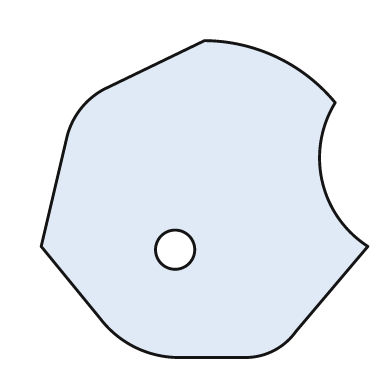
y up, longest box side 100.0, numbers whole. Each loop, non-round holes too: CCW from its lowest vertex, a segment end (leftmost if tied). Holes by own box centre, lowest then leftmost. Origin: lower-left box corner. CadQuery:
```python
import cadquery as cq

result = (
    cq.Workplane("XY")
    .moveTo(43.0, 0.0)
    .lineTo(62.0, 0.0)
    .threePointArc((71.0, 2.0), (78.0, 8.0))
    .lineTo(100.0, 34.0)
    .threePointArc((86.0, 54.0), (90.0, 78.0))
    .threePointArc((72.0, 92.0), (50.0, 97.0))
    .lineTo(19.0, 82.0)
    .threePointArc((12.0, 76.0), (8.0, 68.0))
    .lineTo(0.0, 34.0)
    .lineTo(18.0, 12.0)
    .threePointArc((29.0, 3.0), (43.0, 0.0))
    .close()
    .moveTo(41.0, 33.0)
    .circle(6.0)
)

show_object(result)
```